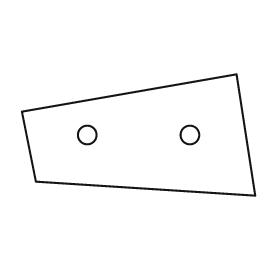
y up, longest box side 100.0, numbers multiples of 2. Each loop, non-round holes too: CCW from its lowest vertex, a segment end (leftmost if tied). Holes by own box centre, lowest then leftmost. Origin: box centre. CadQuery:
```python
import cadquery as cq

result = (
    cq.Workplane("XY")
    .moveTo(50.0, -26.0)
    .lineTo(42.0, 26.0)
    .lineTo(-50.0, 10.0)
    .lineTo(-44.0, -20.0)
    .close()
    .moveTo(-22.0, 0.0)
    .circle(4.0)
    .moveTo(22.0, 0.0)
    .circle(4.0)
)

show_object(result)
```